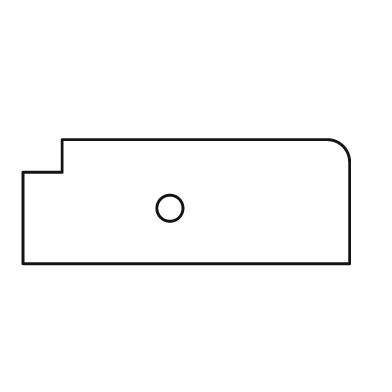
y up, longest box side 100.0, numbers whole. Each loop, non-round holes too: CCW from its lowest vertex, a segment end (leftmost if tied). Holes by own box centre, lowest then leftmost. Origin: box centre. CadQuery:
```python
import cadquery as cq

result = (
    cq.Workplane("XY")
    .moveTo(-50.0, -19.0)
    .lineTo(50.0, -19.0)
    .lineTo(50.0, 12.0)
    .threePointArc((48.0, 17.0), (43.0, 19.0))
    .lineTo(-38.0, 19.0)
    .lineTo(-38.0, 9.0)
    .lineTo(-50.0, 9.0)
    .close()
    .moveTo(-5.0, -2.0)
    .circle(4.0)
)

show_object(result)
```